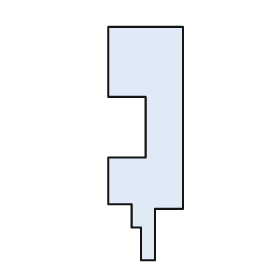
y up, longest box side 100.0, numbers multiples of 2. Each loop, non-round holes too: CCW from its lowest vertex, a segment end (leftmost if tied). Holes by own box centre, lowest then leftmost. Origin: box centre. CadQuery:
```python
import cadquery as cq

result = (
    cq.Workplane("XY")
    .moveTo(-2.0, -50.0)
    .lineTo(4.0, -50.0)
    .lineTo(4.0, -28.0)
    .lineTo(16.0, -28.0)
    .lineTo(16.0, 50.0)
    .lineTo(-16.0, 50.0)
    .lineTo(-16.0, 20.0)
    .lineTo(0.0, 20.0)
    .lineTo(0.0, -6.0)
    .lineTo(-16.0, -6.0)
    .lineTo(-16.0, -26.0)
    .lineTo(-6.0, -26.0)
    .lineTo(-6.0, -36.0)
    .lineTo(-2.0, -36.0)
    .close()
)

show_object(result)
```